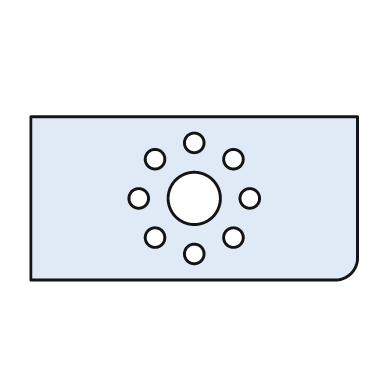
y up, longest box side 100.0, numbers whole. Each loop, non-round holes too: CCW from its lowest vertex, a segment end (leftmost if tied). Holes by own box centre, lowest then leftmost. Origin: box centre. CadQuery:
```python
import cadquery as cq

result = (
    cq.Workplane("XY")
    .moveTo(-50.0, -25.0)
    .lineTo(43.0, -25.0)
    .threePointArc((48.0, -23.0), (50.0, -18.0))
    .lineTo(50.0, 25.0)
    .lineTo(-50.0, 25.0)
    .close()
    .moveTo(0.0, -17.0)
    .circle(3.0)
    .moveTo(-12.0, -12.0)
    .circle(3.0)
    .moveTo(12.0, -12.0)
    .circle(3.0)
    .moveTo(-17.0, 0.0)
    .circle(3.0)
    .moveTo(0.0, 0.0)
    .circle(8.0)
    .moveTo(17.0, 0.0)
    .circle(3.0)
    .moveTo(-12.0, 12.0)
    .circle(3.0)
    .moveTo(12.0, 12.0)
    .circle(3.0)
    .moveTo(0.0, 17.0)
    .circle(3.0)
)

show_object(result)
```